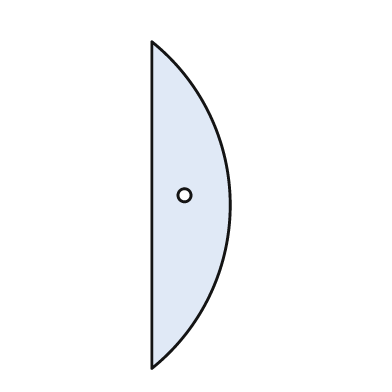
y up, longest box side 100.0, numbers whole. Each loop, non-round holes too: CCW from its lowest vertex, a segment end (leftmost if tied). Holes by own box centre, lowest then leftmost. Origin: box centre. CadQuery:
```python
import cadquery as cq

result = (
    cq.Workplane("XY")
    .moveTo(-12.0, -50.0)
    .threePointArc((12.0, 0.0), (-12.0, 50.0))
    .close()
    .moveTo(-2.0, 3.0)
    .circle(2.0)
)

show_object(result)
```